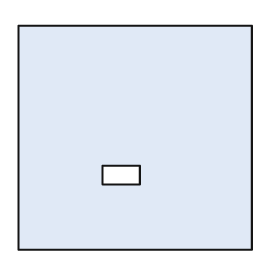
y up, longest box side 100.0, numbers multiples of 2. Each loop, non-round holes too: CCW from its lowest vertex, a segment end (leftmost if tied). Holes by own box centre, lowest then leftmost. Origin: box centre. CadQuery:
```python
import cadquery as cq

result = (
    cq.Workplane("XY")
    .moveTo(-50.0, -48.0)
    .lineTo(50.0, -48.0)
    .lineTo(50.0, 48.0)
    .lineTo(-50.0, 48.0)
    .close()
    .moveTo(-14.0, -20.0)
    .lineTo(2.0, -20.0)
    .lineTo(2.0, -12.0)
    .lineTo(-14.0, -12.0)
    .close()
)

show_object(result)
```